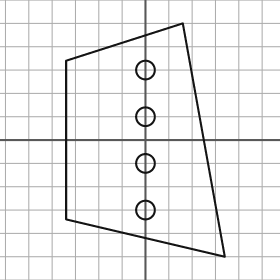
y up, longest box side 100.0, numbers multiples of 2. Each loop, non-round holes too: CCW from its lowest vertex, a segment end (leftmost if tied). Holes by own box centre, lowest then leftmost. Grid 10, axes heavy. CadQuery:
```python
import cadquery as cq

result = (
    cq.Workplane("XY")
    .moveTo(34.0, -50.0)
    .lineTo(16.0, 50.0)
    .lineTo(-34.0, 34.0)
    .lineTo(-34.0, -34.0)
    .close()
    .moveTo(0.0, -30.0)
    .circle(4.0)
    .moveTo(0.0, -10.0)
    .circle(4.0)
    .moveTo(0.0, 10.0)
    .circle(4.0)
    .moveTo(0.0, 30.0)
    .circle(4.0)
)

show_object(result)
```